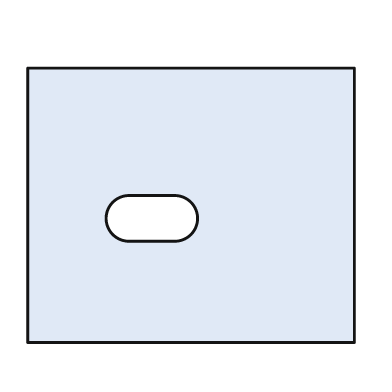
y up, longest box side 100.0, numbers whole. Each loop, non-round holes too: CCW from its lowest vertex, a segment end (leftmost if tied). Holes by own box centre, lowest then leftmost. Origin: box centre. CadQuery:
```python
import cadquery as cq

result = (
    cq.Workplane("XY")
    .moveTo(-50.0, -42.0)
    .lineTo(50.0, -42.0)
    .lineTo(50.0, 42.0)
    .lineTo(-50.0, 42.0)
    .close()
    .moveTo(-19.0, -11.0)
    .lineTo(-5.0, -11.0)
    .threePointArc((2.0, -4.0), (-5.0, 3.0))
    .lineTo(-19.0, 3.0)
    .threePointArc((-26.0, -4.0), (-19.0, -11.0))
    .close()
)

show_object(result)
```